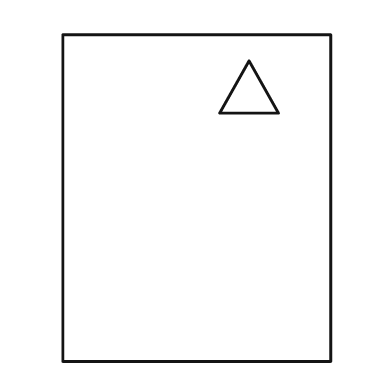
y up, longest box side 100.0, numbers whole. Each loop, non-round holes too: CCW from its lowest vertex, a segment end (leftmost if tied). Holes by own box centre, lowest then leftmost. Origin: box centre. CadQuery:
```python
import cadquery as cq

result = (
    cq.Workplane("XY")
    .moveTo(-41.0, -50.0)
    .lineTo(41.0, -50.0)
    .lineTo(41.0, 50.0)
    .lineTo(-41.0, 50.0)
    .close()
    .moveTo(7.0, 26.0)
    .lineTo(25.0, 26.0)
    .lineTo(16.0, 42.0)
    .close()
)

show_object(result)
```